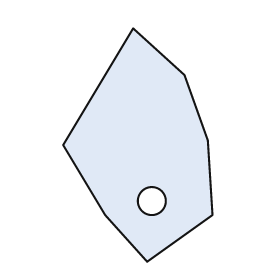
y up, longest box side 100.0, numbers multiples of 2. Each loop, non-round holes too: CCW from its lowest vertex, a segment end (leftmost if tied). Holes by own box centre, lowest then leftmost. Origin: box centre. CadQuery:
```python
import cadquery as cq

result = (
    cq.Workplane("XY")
    .moveTo(4.0, -50.0)
    .lineTo(32.0, -30.0)
    .lineTo(30.0, 2.0)
    .lineTo(20.0, 30.0)
    .lineTo(-2.0, 50.0)
    .lineTo(-32.0, 0.0)
    .lineTo(-14.0, -30.0)
    .close()
    .moveTo(6.0, -24.0)
    .circle(6.0)
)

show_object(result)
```